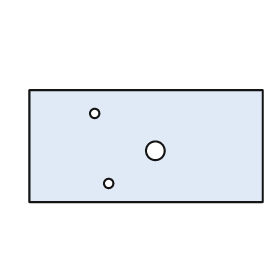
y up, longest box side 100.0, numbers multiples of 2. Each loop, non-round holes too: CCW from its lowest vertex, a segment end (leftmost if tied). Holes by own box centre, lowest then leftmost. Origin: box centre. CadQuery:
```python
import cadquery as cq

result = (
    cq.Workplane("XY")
    .moveTo(-50.0, -24.0)
    .lineTo(50.0, -24.0)
    .lineTo(50.0, 24.0)
    .lineTo(-50.0, 24.0)
    .close()
    .moveTo(-16.0, -16.0)
    .circle(2.0)
    .moveTo(4.0, -2.0)
    .circle(4.0)
    .moveTo(-22.0, 14.0)
    .circle(2.0)
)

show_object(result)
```